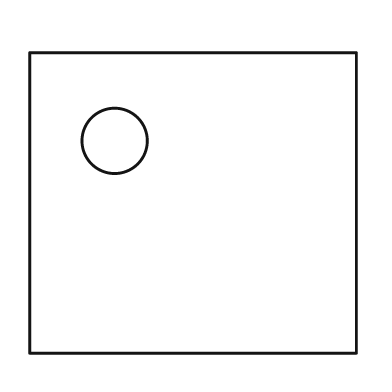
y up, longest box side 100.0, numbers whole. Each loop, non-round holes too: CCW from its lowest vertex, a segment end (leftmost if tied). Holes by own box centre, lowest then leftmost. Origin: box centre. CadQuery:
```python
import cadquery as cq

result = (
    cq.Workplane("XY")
    .moveTo(-50.0, -46.0)
    .lineTo(50.0, -46.0)
    .lineTo(50.0, 46.0)
    .lineTo(-50.0, 46.0)
    .close()
    .moveTo(-24.0, 19.0)
    .circle(10.0)
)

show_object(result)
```